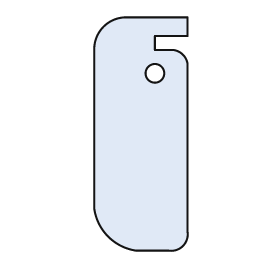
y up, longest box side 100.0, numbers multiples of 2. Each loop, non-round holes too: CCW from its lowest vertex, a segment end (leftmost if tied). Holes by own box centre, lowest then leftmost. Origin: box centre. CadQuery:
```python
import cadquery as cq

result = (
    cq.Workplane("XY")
    .moveTo(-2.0, -50.0)
    .lineTo(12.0, -50.0)
    .threePointArc((18.0, -48.0), (20.0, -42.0))
    .lineTo(20.0, 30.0)
    .threePointArc((18.0, 34.0), (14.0, 36.0))
    .lineTo(6.0, 36.0)
    .lineTo(6.0, 42.0)
    .lineTo(20.0, 42.0)
    .lineTo(20.0, 50.0)
    .lineTo(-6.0, 50.0)
    .threePointArc((-16.0, 46.0), (-20.0, 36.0))
    .lineTo(-20.0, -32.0)
    .threePointArc((-14.0, -44.0), (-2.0, -50.0))
    .close()
    .moveTo(6.0, 26.0)
    .circle(4.0)
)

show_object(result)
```